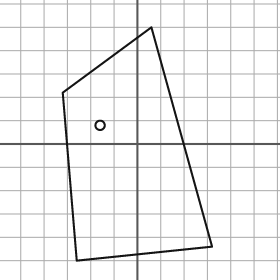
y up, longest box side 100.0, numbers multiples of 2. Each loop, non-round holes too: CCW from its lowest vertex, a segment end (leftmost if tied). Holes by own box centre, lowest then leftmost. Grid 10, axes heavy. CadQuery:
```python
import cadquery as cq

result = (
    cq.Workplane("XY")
    .moveTo(-26.0, -50.0)
    .lineTo(32.0, -44.0)
    .lineTo(6.0, 50.0)
    .lineTo(-32.0, 22.0)
    .close()
    .moveTo(-16.0, 8.0)
    .circle(2.0)
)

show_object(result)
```